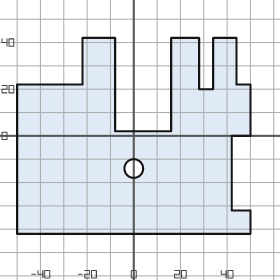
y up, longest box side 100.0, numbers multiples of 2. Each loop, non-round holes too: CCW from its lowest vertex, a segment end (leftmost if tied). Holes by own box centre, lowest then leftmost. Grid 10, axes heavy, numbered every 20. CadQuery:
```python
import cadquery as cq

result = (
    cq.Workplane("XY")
    .moveTo(-50.0, -42.0)
    .lineTo(50.0, -42.0)
    .lineTo(50.0, -32.0)
    .lineTo(42.0, -32.0)
    .lineTo(42.0, 0.0)
    .lineTo(50.0, 0.0)
    .lineTo(50.0, 22.0)
    .lineTo(44.0, 22.0)
    .lineTo(44.0, 42.0)
    .lineTo(34.0, 42.0)
    .lineTo(34.0, 20.0)
    .lineTo(28.0, 20.0)
    .lineTo(28.0, 42.0)
    .lineTo(16.0, 42.0)
    .lineTo(16.0, 2.0)
    .lineTo(-8.0, 2.0)
    .lineTo(-8.0, 42.0)
    .lineTo(-22.0, 42.0)
    .lineTo(-22.0, 22.0)
    .lineTo(-50.0, 22.0)
    .close()
    .moveTo(0.0, -14.0)
    .circle(4.0)
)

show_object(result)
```